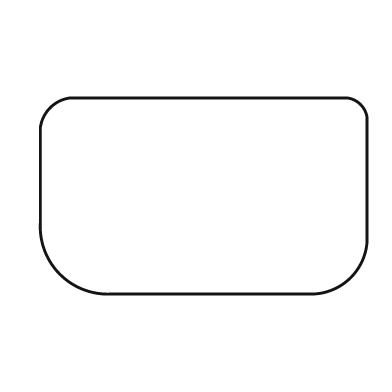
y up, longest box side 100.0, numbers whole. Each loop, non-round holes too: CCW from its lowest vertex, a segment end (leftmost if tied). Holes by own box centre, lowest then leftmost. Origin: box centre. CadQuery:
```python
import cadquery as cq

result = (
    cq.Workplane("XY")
    .moveTo(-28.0, -30.0)
    .lineTo(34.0, -30.0)
    .threePointArc((45.0, -25.0), (50.0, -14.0))
    .lineTo(50.0, 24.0)
    .threePointArc((48.0, 28.0), (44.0, 30.0))
    .lineTo(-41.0, 30.0)
    .threePointArc((-47.0, 27.0), (-50.0, 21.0))
    .lineTo(-50.0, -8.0)
    .threePointArc((-44.0, -24.0), (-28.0, -30.0))
    .close()
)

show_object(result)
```